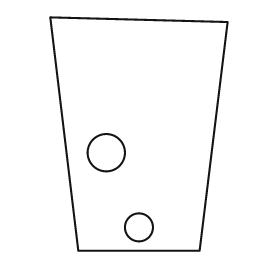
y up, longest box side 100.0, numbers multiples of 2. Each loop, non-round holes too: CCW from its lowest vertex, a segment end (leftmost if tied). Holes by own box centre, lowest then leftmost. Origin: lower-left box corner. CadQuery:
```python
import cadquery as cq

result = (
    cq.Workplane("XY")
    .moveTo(12.0, 0.0)
    .lineTo(64.0, 0.0)
    .lineTo(76.0, 98.0)
    .lineTo(0.0, 100.0)
    .close()
    .moveTo(38.0, 10.0)
    .circle(6.0)
    .moveTo(24.0, 42.0)
    .circle(8.0)
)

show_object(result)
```